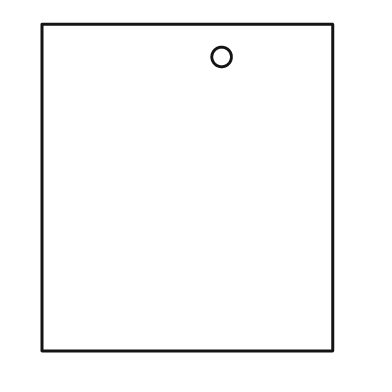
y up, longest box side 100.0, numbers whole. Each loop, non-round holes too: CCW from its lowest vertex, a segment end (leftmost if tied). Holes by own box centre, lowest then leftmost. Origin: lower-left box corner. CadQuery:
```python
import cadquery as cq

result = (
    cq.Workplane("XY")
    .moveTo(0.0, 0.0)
    .lineTo(89.0, 0.0)
    .lineTo(89.0, 100.0)
    .lineTo(0.0, 100.0)
    .close()
    .moveTo(55.0, 90.0)
    .circle(3.0)
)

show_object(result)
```